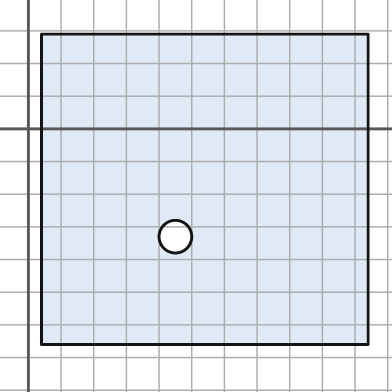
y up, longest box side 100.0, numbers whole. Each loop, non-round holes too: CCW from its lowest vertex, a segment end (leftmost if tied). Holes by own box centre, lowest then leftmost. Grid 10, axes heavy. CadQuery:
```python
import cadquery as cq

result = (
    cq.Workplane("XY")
    .moveTo(4.0, -66.0)
    .lineTo(104.0, -66.0)
    .lineTo(104.0, 29.0)
    .lineTo(4.0, 29.0)
    .close()
    .moveTo(45.0, -33.0)
    .circle(5.0)
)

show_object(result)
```